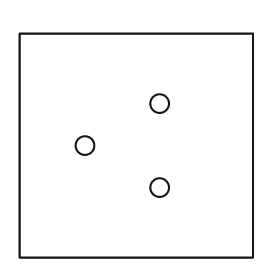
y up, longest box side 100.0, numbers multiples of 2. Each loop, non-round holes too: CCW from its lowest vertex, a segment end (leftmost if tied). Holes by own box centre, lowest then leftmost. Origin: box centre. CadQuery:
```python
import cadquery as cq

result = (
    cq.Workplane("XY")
    .moveTo(-50.0, -48.0)
    .lineTo(50.0, -48.0)
    .lineTo(50.0, 48.0)
    .lineTo(-50.0, 48.0)
    .close()
    .moveTo(10.0, -18.0)
    .circle(4.0)
    .moveTo(-22.0, 0.0)
    .circle(4.0)
    .moveTo(10.0, 18.0)
    .circle(4.0)
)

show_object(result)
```